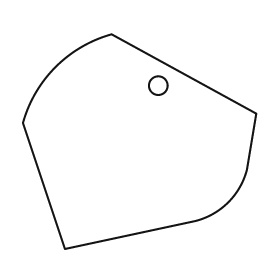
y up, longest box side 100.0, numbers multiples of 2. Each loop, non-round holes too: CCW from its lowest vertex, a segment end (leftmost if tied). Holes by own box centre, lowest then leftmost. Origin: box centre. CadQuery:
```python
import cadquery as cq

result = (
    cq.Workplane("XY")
    .moveTo(-32.0, -46.0)
    .lineTo(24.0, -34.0)
    .threePointArc((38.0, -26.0), (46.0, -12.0))
    .lineTo(50.0, 12.0)
    .lineTo(-12.0, 46.0)
    .threePointArc((-36.0, 32.0), (-50.0, 8.0))
    .close()
    .moveTo(8.0, 24.0)
    .circle(4.0)
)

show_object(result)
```